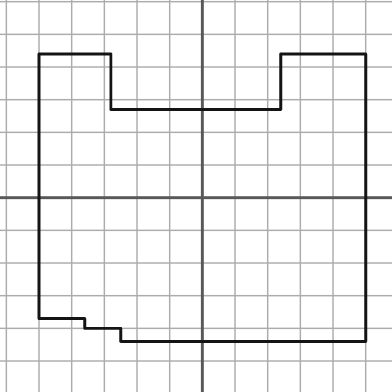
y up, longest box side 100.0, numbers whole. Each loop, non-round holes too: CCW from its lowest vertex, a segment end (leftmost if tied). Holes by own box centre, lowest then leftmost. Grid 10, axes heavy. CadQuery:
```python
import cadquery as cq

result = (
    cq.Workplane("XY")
    .moveTo(-25.0, -44.0)
    .lineTo(50.0, -44.0)
    .lineTo(50.0, 44.0)
    .lineTo(24.0, 44.0)
    .lineTo(24.0, 27.0)
    .lineTo(-28.0, 27.0)
    .lineTo(-28.0, 44.0)
    .lineTo(-50.0, 44.0)
    .lineTo(-50.0, -37.0)
    .lineTo(-36.0, -37.0)
    .lineTo(-36.0, -40.0)
    .lineTo(-25.0, -40.0)
    .close()
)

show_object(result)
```